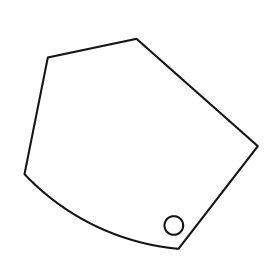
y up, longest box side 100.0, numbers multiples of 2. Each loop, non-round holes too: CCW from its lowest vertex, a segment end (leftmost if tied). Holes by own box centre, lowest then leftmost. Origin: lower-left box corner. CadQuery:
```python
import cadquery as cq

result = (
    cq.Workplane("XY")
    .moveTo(66.0, 0.0)
    .lineTo(100.0, 44.0)
    .lineTo(48.0, 90.0)
    .lineTo(10.0, 82.0)
    .lineTo(0.0, 32.0)
    .threePointArc((30.0, 10.0), (66.0, 0.0))
    .close()
    .moveTo(64.0, 10.0)
    .circle(4.0)
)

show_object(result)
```